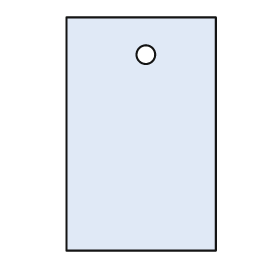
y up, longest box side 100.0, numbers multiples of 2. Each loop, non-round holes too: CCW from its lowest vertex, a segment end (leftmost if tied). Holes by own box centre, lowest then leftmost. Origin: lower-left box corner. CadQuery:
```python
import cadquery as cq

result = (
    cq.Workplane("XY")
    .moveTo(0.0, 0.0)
    .lineTo(64.0, 0.0)
    .lineTo(64.0, 100.0)
    .lineTo(0.0, 100.0)
    .close()
    .moveTo(34.0, 84.0)
    .circle(4.0)
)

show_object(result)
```